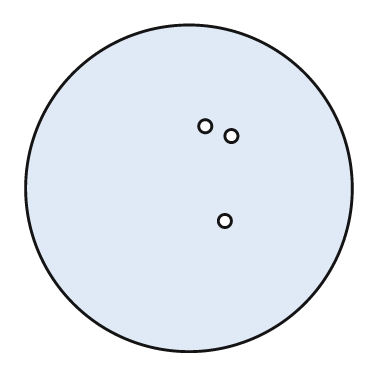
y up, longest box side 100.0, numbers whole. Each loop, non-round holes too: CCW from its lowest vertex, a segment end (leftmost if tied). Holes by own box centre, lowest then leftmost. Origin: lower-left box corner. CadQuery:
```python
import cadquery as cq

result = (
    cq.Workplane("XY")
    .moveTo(50.0, 50.0)
    .circle(50.0)
    .moveTo(61.0, 40.0)
    .circle(2.0)
    .moveTo(63.0, 66.0)
    .circle(2.0)
    .moveTo(55.0, 69.0)
    .circle(2.0)
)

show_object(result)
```